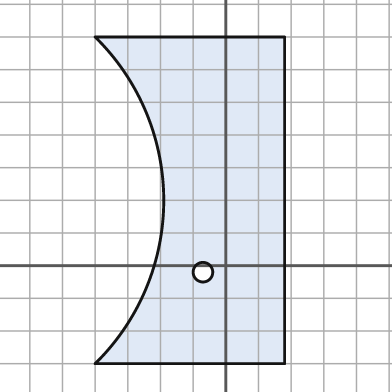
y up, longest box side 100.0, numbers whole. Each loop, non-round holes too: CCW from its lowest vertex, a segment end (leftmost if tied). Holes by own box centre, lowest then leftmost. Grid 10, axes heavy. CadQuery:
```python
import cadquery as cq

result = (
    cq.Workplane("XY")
    .moveTo(-40.0, -30.0)
    .lineTo(18.0, -30.0)
    .lineTo(18.0, 70.0)
    .lineTo(-40.0, 70.0)
    .threePointArc((-19.0, 20.0), (-40.0, -30.0))
    .close()
    .moveTo(-7.0, -2.0)
    .circle(3.0)
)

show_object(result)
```